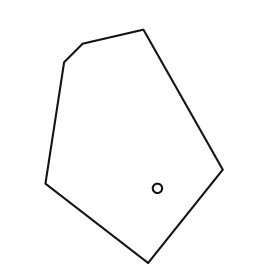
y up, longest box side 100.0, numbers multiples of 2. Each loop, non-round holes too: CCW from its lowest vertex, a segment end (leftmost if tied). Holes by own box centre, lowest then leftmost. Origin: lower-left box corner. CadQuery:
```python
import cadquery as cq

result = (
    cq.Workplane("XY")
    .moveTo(44.0, 0.0)
    .lineTo(76.0, 40.0)
    .lineTo(42.0, 100.0)
    .lineTo(16.0, 94.0)
    .lineTo(8.0, 86.0)
    .lineTo(0.0, 34.0)
    .close()
    .moveTo(48.0, 32.0)
    .circle(2.0)
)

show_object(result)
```